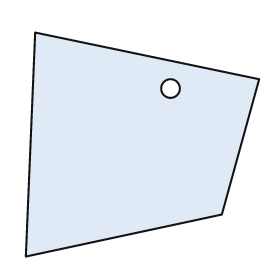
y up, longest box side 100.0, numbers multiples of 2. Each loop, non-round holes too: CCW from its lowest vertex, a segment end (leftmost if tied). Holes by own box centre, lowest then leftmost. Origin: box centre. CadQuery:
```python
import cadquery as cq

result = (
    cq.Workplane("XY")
    .moveTo(-50.0, -48.0)
    .lineTo(34.0, -30.0)
    .lineTo(50.0, 28.0)
    .lineTo(-46.0, 48.0)
    .close()
    .moveTo(12.0, 24.0)
    .circle(4.0)
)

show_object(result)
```